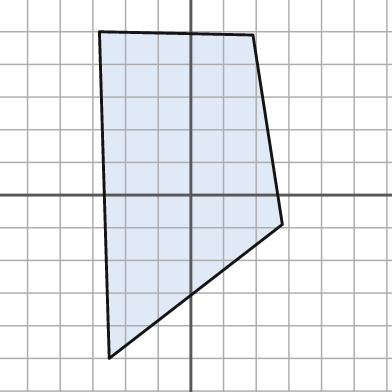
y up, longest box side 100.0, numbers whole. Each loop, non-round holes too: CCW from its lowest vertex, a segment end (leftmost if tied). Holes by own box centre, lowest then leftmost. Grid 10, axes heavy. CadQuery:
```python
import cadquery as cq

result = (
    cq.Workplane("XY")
    .moveTo(-25.0, -50.0)
    .lineTo(28.0, -9.0)
    .lineTo(19.0, 49.0)
    .lineTo(-28.0, 50.0)
    .close()
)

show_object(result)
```